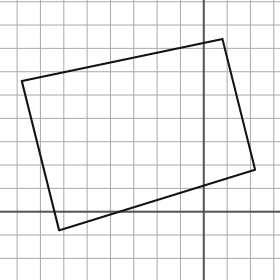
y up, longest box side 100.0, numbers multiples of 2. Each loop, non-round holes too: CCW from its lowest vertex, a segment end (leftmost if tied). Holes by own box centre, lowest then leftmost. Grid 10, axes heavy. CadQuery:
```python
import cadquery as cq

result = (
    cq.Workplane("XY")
    .moveTo(-62.0, -8.0)
    .lineTo(22.0, 18.0)
    .lineTo(8.0, 74.0)
    .lineTo(-78.0, 56.0)
    .close()
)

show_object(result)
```